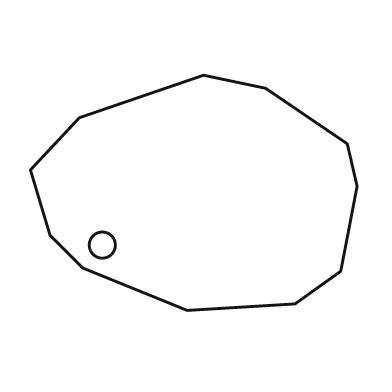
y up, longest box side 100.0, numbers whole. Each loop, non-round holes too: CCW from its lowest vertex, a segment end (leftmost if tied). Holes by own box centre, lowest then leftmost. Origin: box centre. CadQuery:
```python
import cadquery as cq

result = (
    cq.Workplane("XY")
    .moveTo(-2.0, -36.0)
    .lineTo(31.0, -34.0)
    .lineTo(45.0, -24.0)
    .lineTo(50.0, 2.0)
    .lineTo(47.0, 15.0)
    .lineTo(22.0, 32.0)
    .lineTo(3.0, 36.0)
    .lineTo(-35.0, 23.0)
    .lineTo(-50.0, 7.0)
    .lineTo(-44.0, -13.0)
    .lineTo(-34.0, -23.0)
    .close()
    .moveTo(-28.0, -16.0)
    .circle(4.0)
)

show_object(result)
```